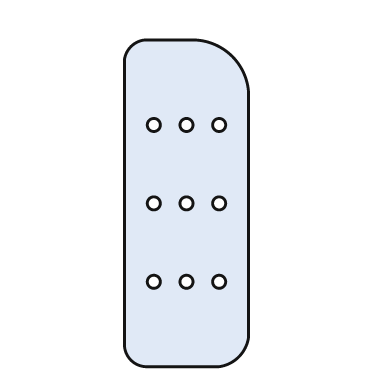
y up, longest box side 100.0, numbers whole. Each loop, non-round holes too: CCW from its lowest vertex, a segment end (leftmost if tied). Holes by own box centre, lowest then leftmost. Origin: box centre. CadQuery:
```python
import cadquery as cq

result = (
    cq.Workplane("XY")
    .moveTo(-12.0, -50.0)
    .lineTo(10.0, -50.0)
    .threePointArc((16.0, -47.0), (19.0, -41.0))
    .lineTo(19.0, 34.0)
    .threePointArc((14.0, 45.0), (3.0, 50.0))
    .lineTo(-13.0, 50.0)
    .threePointArc((-17.0, 48.0), (-19.0, 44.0))
    .lineTo(-19.0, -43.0)
    .threePointArc((-17.0, -48.0), (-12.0, -50.0))
    .close()
    .moveTo(-10.0, -24.0)
    .circle(2.0)
    .moveTo(0.0, -24.0)
    .circle(2.0)
    .moveTo(10.0, -24.0)
    .circle(2.0)
    .moveTo(-10.0, 0.0)
    .circle(2.0)
    .moveTo(0.0, 0.0)
    .circle(2.0)
    .moveTo(10.0, 0.0)
    .circle(2.0)
    .moveTo(-10.0, 24.0)
    .circle(2.0)
    .moveTo(0.0, 24.0)
    .circle(2.0)
    .moveTo(10.0, 24.0)
    .circle(2.0)
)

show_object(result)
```